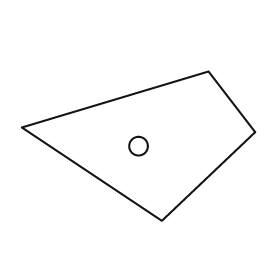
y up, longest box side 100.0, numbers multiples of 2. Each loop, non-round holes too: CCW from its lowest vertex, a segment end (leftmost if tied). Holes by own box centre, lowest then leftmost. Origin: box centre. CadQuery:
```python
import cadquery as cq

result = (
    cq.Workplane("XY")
    .moveTo(10.0, -32.0)
    .lineTo(50.0, 6.0)
    .lineTo(30.0, 32.0)
    .lineTo(-50.0, 8.0)
    .close()
    .moveTo(0.0, 0.0)
    .circle(4.0)
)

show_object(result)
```